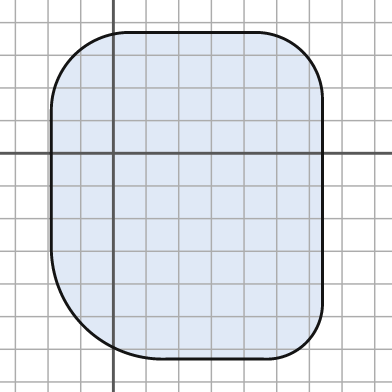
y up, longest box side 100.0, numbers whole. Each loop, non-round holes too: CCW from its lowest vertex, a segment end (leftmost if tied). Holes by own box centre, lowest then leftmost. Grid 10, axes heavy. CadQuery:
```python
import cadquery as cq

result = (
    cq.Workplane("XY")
    .moveTo(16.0, -63.0)
    .lineTo(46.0, -63.0)
    .threePointArc((59.0, -58.0), (64.0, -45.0))
    .lineTo(64.0, 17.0)
    .threePointArc((58.0, 31.0), (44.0, 37.0))
    .lineTo(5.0, 37.0)
    .threePointArc((-12.0, 30.0), (-19.0, 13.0))
    .lineTo(-19.0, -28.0)
    .threePointArc((-9.0, -53.0), (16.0, -63.0))
    .close()
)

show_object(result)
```